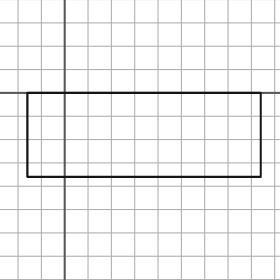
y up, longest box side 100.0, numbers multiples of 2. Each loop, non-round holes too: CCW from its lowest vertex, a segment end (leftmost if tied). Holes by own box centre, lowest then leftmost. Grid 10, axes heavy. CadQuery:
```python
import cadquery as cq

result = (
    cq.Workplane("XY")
    .moveTo(-16.0, -36.0)
    .lineTo(84.0, -36.0)
    .lineTo(84.0, 0.0)
    .lineTo(-16.0, 0.0)
    .close()
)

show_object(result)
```